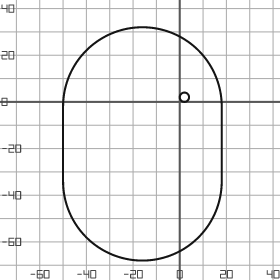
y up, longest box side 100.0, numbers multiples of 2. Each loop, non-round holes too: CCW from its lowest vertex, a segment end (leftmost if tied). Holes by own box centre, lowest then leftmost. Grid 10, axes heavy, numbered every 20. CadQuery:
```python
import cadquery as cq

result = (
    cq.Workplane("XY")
    .moveTo(-50.0, -34.0)
    .threePointArc((-16.0, -68.0), (18.0, -34.0))
    .lineTo(18.0, -2.0)
    .threePointArc((-16.0, 32.0), (-50.0, -2.0))
    .close()
    .moveTo(2.0, 2.0)
    .circle(2.0)
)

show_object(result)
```